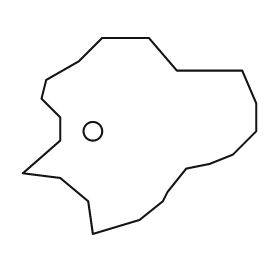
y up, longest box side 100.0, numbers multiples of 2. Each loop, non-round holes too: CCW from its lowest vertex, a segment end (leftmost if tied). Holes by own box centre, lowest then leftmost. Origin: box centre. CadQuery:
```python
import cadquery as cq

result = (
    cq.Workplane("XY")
    .moveTo(-20.0, -42.0)
    .lineTo(0.0, -36.0)
    .lineTo(10.0, -28.0)
    .lineTo(12.0, -24.0)
    .lineTo(20.0, -14.0)
    .lineTo(30.0, -12.0)
    .lineTo(40.0, -8.0)
    .lineTo(50.0, 2.0)
    .lineTo(50.0, 14.0)
    .lineTo(44.0, 28.0)
    .lineTo(16.0, 28.0)
    .lineTo(4.0, 42.0)
    .lineTo(-16.0, 42.0)
    .lineTo(-26.0, 32.0)
    .lineTo(-40.0, 24.0)
    .lineTo(-42.0, 16.0)
    .lineTo(-34.0, 8.0)
    .lineTo(-34.0, -2.0)
    .lineTo(-50.0, -16.0)
    .lineTo(-34.0, -18.0)
    .lineTo(-22.0, -28.0)
    .close()
    .moveTo(-20.0, 2.0)
    .circle(4.0)
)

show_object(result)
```